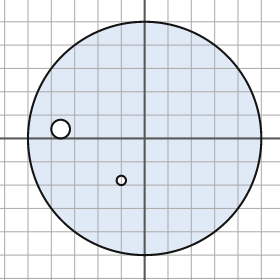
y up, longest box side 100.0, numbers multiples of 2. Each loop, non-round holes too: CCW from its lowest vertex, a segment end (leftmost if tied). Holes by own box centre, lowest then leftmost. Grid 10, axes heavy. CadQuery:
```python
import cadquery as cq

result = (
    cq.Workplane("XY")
    .moveTo(0.0, 0.0)
    .circle(50.0)
    .moveTo(-10.0, -18.0)
    .circle(2.0)
    .moveTo(-36.0, 4.0)
    .circle(4.0)
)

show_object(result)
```